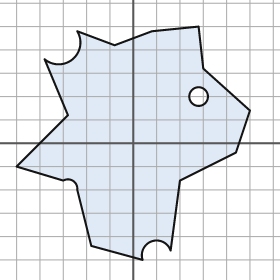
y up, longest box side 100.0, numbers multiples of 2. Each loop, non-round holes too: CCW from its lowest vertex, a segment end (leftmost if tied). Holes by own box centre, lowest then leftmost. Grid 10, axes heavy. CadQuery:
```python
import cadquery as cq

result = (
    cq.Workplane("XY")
    .moveTo(4.0, -50.0)
    .threePointArc((8.0, -42.0), (16.0, -46.0))
    .lineTo(20.0, -16.0)
    .lineTo(44.0, -4.0)
    .lineTo(50.0, 14.0)
    .lineTo(30.0, 32.0)
    .lineTo(28.0, 50.0)
    .lineTo(8.0, 48.0)
    .lineTo(-8.0, 42.0)
    .lineTo(-24.0, 48.0)
    .threePointArc((-26.0, 36.0), (-38.0, 36.0))
    .lineTo(-28.0, 12.0)
    .lineTo(-50.0, -10.0)
    .lineTo(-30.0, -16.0)
    .threePointArc((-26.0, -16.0), (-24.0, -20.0))
    .lineTo(-18.0, -44.0)
    .close()
    .moveTo(28.0, 20.0)
    .circle(4.0)
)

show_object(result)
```